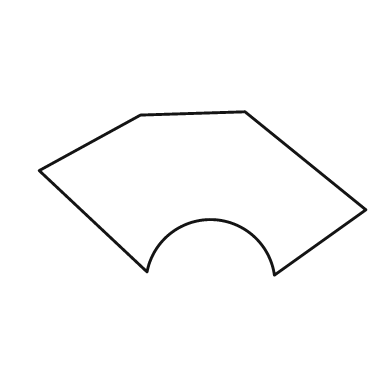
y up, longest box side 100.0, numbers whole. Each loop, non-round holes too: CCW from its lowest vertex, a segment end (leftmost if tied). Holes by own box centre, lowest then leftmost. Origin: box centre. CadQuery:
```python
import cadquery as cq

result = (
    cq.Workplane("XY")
    .moveTo(22.0, -25.0)
    .lineTo(50.0, -5.0)
    .lineTo(13.0, 25.0)
    .lineTo(-19.0, 24.0)
    .lineTo(-50.0, 7.0)
    .lineTo(-17.0, -24.0)
    .threePointArc((3.0, -8.0), (22.0, -25.0))
    .close()
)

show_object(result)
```